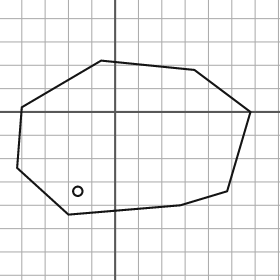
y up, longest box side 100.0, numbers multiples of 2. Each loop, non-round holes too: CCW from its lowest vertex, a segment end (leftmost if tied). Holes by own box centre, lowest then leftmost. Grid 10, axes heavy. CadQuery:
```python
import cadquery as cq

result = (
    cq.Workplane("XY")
    .moveTo(-20.0, -44.0)
    .lineTo(28.0, -40.0)
    .lineTo(48.0, -34.0)
    .lineTo(58.0, 0.0)
    .lineTo(34.0, 18.0)
    .lineTo(-6.0, 22.0)
    .lineTo(-40.0, 2.0)
    .lineTo(-42.0, -24.0)
    .close()
    .moveTo(-16.0, -34.0)
    .circle(2.0)
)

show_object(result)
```